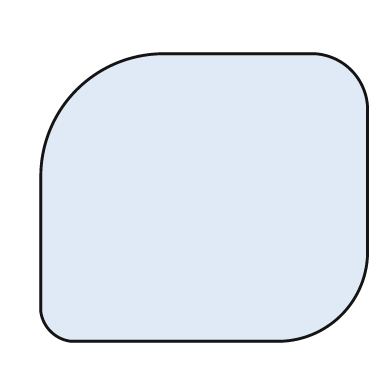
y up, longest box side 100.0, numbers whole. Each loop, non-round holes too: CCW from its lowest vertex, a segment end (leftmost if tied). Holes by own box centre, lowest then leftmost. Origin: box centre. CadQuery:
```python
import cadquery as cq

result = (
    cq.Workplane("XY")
    .moveTo(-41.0, -44.0)
    .lineTo(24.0, -44.0)
    .threePointArc((42.0, -36.0), (50.0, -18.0))
    .lineTo(50.0, 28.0)
    .threePointArc((45.0, 39.0), (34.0, 44.0))
    .lineTo(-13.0, 44.0)
    .threePointArc((-39.0, 33.0), (-50.0, 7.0))
    .lineTo(-50.0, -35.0)
    .threePointArc((-47.0, -41.0), (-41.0, -44.0))
    .close()
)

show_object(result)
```